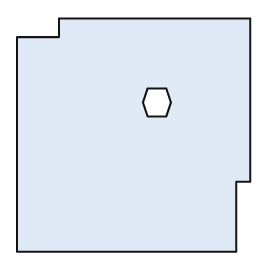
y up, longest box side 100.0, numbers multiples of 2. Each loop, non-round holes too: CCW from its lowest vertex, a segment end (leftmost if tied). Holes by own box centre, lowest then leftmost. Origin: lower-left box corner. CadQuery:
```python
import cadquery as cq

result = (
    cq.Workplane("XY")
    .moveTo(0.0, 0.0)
    .lineTo(94.0, 0.0)
    .lineTo(94.0, 30.0)
    .lineTo(100.0, 30.0)
    .lineTo(100.0, 100.0)
    .lineTo(18.0, 100.0)
    .lineTo(18.0, 92.0)
    .lineTo(0.0, 92.0)
    .close()
    .moveTo(56.0, 58.0)
    .lineTo(64.0, 58.0)
    .lineTo(66.0, 64.0)
    .lineTo(64.0, 70.0)
    .lineTo(56.0, 70.0)
    .lineTo(54.0, 64.0)
    .close()
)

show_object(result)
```